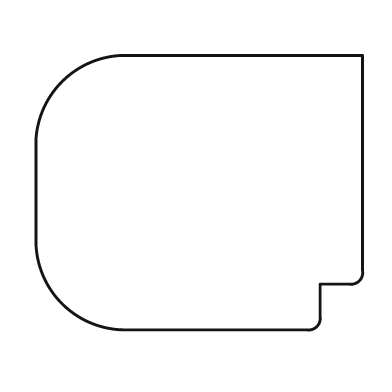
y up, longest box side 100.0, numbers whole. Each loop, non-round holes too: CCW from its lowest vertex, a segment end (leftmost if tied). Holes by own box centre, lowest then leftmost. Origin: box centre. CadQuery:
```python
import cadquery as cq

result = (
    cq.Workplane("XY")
    .moveTo(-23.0, -42.0)
    .lineTo(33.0, -42.0)
    .threePointArc((36.0, -41.0), (37.0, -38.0))
    .lineTo(37.0, -28.0)
    .lineTo(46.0, -28.0)
    .threePointArc((49.0, -27.0), (50.0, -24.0))
    .lineTo(50.0, 42.0)
    .lineTo(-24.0, 42.0)
    .threePointArc((-42.0, 34.0), (-50.0, 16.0))
    .lineTo(-50.0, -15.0)
    .threePointArc((-42.0, -34.0), (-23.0, -42.0))
    .close()
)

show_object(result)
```